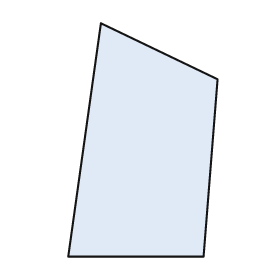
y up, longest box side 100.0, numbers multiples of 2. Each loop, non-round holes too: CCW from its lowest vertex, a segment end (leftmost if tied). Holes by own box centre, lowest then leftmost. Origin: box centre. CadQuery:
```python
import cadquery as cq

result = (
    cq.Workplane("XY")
    .moveTo(-32.0, -50.0)
    .lineTo(26.0, -50.0)
    .lineTo(32.0, 26.0)
    .lineTo(-18.0, 50.0)
    .close()
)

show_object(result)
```